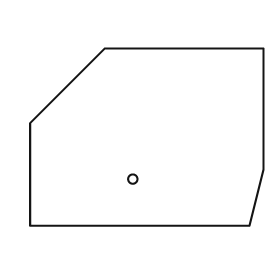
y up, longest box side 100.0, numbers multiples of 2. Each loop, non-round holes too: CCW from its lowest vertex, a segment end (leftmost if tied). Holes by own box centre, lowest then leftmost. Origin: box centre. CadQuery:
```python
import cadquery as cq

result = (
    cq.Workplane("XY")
    .moveTo(-50.0, -38.0)
    .lineTo(44.0, -38.0)
    .lineTo(50.0, -14.0)
    .lineTo(50.0, 38.0)
    .lineTo(-18.0, 38.0)
    .lineTo(-50.0, 6.0)
    .close()
    .moveTo(-6.0, -18.0)
    .circle(2.0)
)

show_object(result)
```